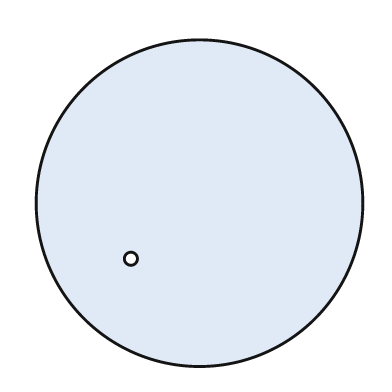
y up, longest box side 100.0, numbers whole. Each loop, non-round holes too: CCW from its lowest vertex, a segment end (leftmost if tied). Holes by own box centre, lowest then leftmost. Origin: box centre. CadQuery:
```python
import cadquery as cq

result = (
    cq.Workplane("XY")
    .moveTo(0.0, 0.0)
    .circle(50.0)
    .moveTo(-21.0, -17.0)
    .circle(2.0)
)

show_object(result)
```